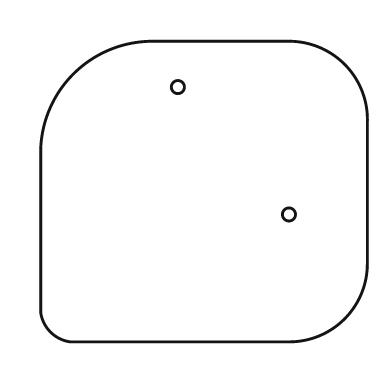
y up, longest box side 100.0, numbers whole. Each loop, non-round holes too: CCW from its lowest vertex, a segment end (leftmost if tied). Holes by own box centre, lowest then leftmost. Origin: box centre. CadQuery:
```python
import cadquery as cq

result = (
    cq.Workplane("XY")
    .moveTo(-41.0, -46.0)
    .lineTo(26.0, -46.0)
    .threePointArc((43.0, -39.0), (50.0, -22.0))
    .lineTo(50.0, 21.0)
    .threePointArc((43.0, 39.0), (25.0, 46.0))
    .lineTo(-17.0, 46.0)
    .threePointArc((-40.0, 36.0), (-50.0, 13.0))
    .lineTo(-50.0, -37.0)
    .threePointArc((-47.0, -43.0), (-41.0, -46.0))
    .close()
    .moveTo(26.0, -7.0)
    .circle(2.0)
    .moveTo(-8.0, 32.0)
    .circle(2.0)
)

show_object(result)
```